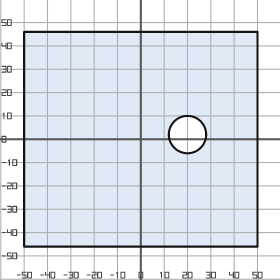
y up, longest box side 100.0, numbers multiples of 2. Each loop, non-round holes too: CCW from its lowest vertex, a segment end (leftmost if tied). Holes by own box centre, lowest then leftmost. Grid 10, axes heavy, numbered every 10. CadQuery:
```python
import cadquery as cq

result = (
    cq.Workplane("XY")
    .moveTo(-50.0, -46.0)
    .lineTo(50.0, -46.0)
    .lineTo(50.0, 46.0)
    .lineTo(-50.0, 46.0)
    .close()
    .moveTo(20.0, 2.0)
    .circle(8.0)
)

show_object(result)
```